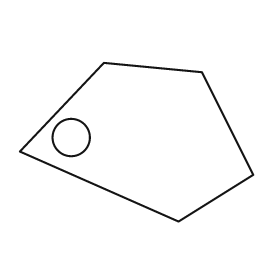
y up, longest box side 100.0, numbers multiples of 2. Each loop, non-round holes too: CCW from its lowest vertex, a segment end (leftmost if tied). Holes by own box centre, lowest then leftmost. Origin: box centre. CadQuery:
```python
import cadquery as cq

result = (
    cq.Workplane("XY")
    .moveTo(18.0, -34.0)
    .lineTo(50.0, -14.0)
    .lineTo(28.0, 30.0)
    .lineTo(-14.0, 34.0)
    .lineTo(-50.0, -4.0)
    .close()
    .moveTo(-28.0, 2.0)
    .circle(8.0)
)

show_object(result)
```